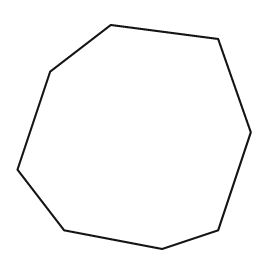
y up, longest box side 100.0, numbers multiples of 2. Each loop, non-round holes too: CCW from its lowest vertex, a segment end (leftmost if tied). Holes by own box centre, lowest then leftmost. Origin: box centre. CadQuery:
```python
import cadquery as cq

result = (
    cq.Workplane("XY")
    .moveTo(12.0, -48.0)
    .lineTo(36.0, -40.0)
    .lineTo(50.0, 2.0)
    .lineTo(36.0, 42.0)
    .lineTo(-10.0, 48.0)
    .lineTo(-36.0, 28.0)
    .lineTo(-50.0, -14.0)
    .lineTo(-30.0, -40.0)
    .close()
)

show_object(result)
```